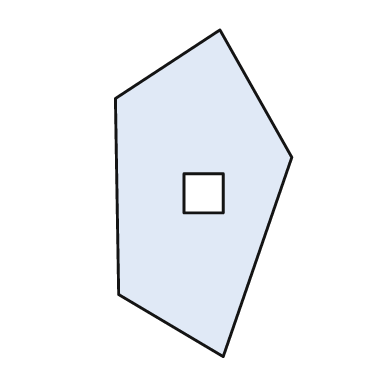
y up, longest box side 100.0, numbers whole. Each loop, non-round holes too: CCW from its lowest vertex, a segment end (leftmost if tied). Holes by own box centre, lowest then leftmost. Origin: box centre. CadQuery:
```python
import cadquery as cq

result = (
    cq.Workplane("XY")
    .moveTo(6.0, -50.0)
    .lineTo(27.0, 11.0)
    .lineTo(5.0, 50.0)
    .lineTo(-27.0, 29.0)
    .lineTo(-26.0, -31.0)
    .close()
    .moveTo(-6.0, -6.0)
    .lineTo(6.0, -6.0)
    .lineTo(6.0, 6.0)
    .lineTo(-6.0, 6.0)
    .close()
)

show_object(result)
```